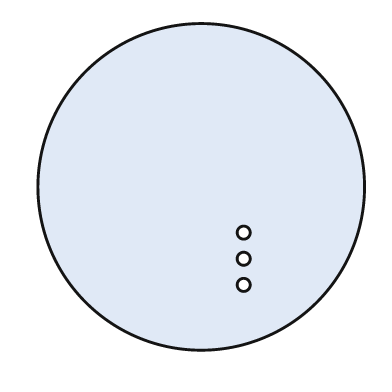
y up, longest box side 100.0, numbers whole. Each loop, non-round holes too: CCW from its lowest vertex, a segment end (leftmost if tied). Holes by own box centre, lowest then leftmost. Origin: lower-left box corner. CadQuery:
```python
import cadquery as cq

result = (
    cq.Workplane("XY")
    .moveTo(50.0, 50.0)
    .circle(50.0)
    .moveTo(63.0, 20.0)
    .circle(2.0)
    .moveTo(63.0, 28.0)
    .circle(2.0)
    .moveTo(63.0, 36.0)
    .circle(2.0)
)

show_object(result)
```